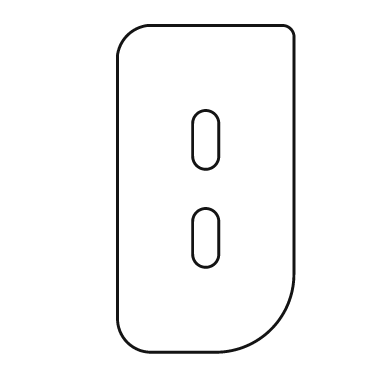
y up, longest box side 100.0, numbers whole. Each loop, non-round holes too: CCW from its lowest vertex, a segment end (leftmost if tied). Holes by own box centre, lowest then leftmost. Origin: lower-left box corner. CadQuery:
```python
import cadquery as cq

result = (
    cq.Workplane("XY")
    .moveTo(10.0, 0.0)
    .lineTo(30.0, 0.0)
    .threePointArc((47.0, 7.0), (54.0, 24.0))
    .lineTo(54.0, 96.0)
    .threePointArc((53.0, 99.0), (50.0, 100.0))
    .lineTo(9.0, 100.0)
    .threePointArc((3.0, 97.0), (0.0, 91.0))
    .lineTo(0.0, 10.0)
    .threePointArc((3.0, 3.0), (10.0, 0.0))
    .close()
    .moveTo(23.0, 30.0)
    .threePointArc((27.0, 26.0), (31.0, 30.0))
    .lineTo(31.0, 40.0)
    .threePointArc((27.0, 44.0), (23.0, 40.0))
    .close()
    .moveTo(23.0, 60.0)
    .threePointArc((27.0, 56.0), (31.0, 60.0))
    .lineTo(31.0, 70.0)
    .threePointArc((27.0, 74.0), (23.0, 70.0))
    .close()
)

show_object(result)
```